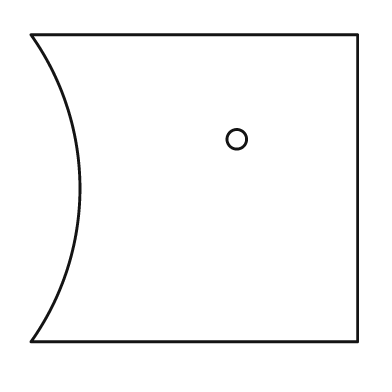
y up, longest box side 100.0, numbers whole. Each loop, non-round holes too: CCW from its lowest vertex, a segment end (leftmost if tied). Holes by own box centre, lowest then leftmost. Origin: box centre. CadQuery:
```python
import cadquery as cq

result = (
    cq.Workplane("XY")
    .moveTo(-50.0, -47.0)
    .lineTo(50.0, -47.0)
    .lineTo(50.0, 47.0)
    .lineTo(-50.0, 47.0)
    .threePointArc((-35.0, 0.0), (-50.0, -47.0))
    .close()
    .moveTo(13.0, 15.0)
    .circle(3.0)
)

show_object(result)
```